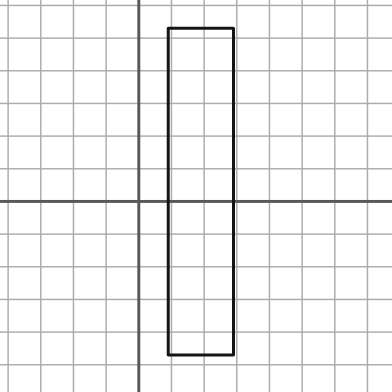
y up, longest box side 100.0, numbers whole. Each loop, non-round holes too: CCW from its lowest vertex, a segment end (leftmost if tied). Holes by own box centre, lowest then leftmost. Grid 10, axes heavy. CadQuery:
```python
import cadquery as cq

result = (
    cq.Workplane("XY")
    .moveTo(9.0, -47.0)
    .lineTo(29.0, -47.0)
    .lineTo(29.0, 53.0)
    .lineTo(9.0, 53.0)
    .close()
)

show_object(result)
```